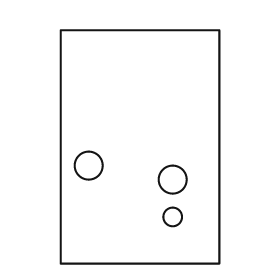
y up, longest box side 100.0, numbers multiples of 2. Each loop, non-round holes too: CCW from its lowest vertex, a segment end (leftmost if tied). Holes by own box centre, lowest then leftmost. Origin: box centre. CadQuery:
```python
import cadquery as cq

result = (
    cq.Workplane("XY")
    .moveTo(-34.0, -50.0)
    .lineTo(34.0, -50.0)
    .lineTo(34.0, 50.0)
    .lineTo(-34.0, 50.0)
    .close()
    .moveTo(14.0, -30.0)
    .circle(4.0)
    .moveTo(14.0, -14.0)
    .circle(6.0)
    .moveTo(-22.0, -8.0)
    .circle(6.0)
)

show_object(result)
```